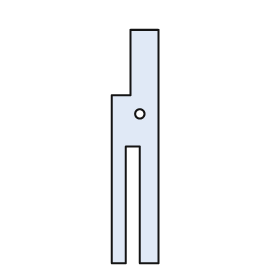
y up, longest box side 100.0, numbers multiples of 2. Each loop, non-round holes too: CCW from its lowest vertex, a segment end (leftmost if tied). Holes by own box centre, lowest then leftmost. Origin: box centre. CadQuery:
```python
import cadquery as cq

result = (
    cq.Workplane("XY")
    .moveTo(-10.0, -50.0)
    .lineTo(-4.0, -50.0)
    .lineTo(-4.0, 0.0)
    .lineTo(2.0, 0.0)
    .lineTo(2.0, -50.0)
    .lineTo(10.0, -50.0)
    .lineTo(10.0, 50.0)
    .lineTo(-2.0, 50.0)
    .lineTo(-2.0, 22.0)
    .lineTo(-10.0, 22.0)
    .close()
    .moveTo(2.0, 14.0)
    .circle(2.0)
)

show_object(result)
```